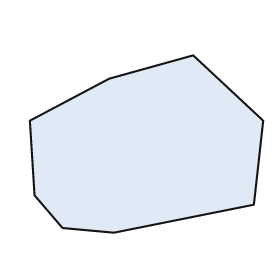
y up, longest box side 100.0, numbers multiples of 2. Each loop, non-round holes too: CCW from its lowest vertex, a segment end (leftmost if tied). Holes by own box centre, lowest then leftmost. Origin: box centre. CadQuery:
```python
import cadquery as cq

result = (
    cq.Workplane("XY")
    .moveTo(-14.0, -38.0)
    .lineTo(46.0, -26.0)
    .lineTo(50.0, 10.0)
    .lineTo(20.0, 38.0)
    .lineTo(-16.0, 28.0)
    .lineTo(-50.0, 10.0)
    .lineTo(-48.0, -22.0)
    .lineTo(-36.0, -36.0)
    .close()
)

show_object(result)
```